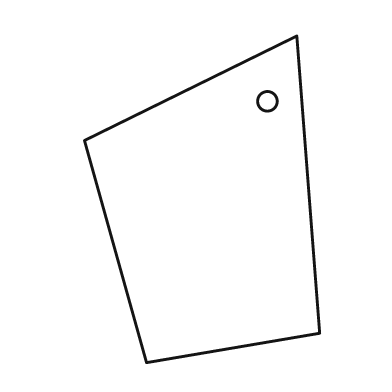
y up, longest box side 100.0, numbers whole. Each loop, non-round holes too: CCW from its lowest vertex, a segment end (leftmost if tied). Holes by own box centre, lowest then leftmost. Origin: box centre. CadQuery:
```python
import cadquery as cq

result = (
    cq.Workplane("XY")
    .moveTo(-17.0, -50.0)
    .lineTo(36.0, -41.0)
    .lineTo(29.0, 50.0)
    .lineTo(-36.0, 18.0)
    .close()
    .moveTo(20.0, 30.0)
    .circle(3.0)
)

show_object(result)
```